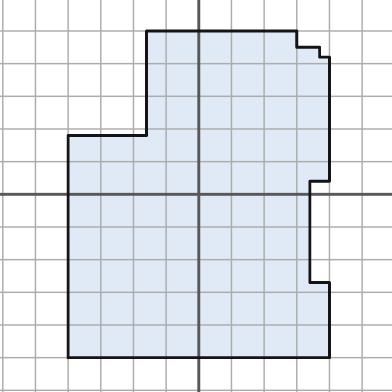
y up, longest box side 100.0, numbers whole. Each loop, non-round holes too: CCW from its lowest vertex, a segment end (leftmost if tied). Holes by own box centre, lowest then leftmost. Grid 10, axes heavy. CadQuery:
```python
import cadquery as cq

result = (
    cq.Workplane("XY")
    .moveTo(-40.0, -50.0)
    .lineTo(40.0, -50.0)
    .lineTo(40.0, -27.0)
    .lineTo(34.0, -27.0)
    .lineTo(34.0, 4.0)
    .lineTo(40.0, 4.0)
    .lineTo(40.0, 42.0)
    .lineTo(37.0, 42.0)
    .lineTo(37.0, 45.0)
    .lineTo(30.0, 45.0)
    .lineTo(30.0, 50.0)
    .lineTo(-16.0, 50.0)
    .lineTo(-16.0, 18.0)
    .lineTo(-40.0, 18.0)
    .close()
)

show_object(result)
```